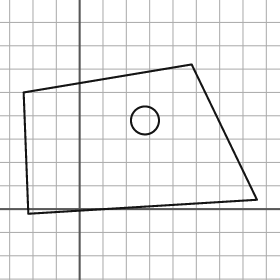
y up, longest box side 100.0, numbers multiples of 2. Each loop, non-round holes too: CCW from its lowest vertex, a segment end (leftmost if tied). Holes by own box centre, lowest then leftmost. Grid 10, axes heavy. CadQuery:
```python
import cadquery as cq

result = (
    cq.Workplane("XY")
    .moveTo(-22.0, -2.0)
    .lineTo(76.0, 4.0)
    .lineTo(48.0, 62.0)
    .lineTo(-24.0, 50.0)
    .close()
    .moveTo(28.0, 38.0)
    .circle(6.0)
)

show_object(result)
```